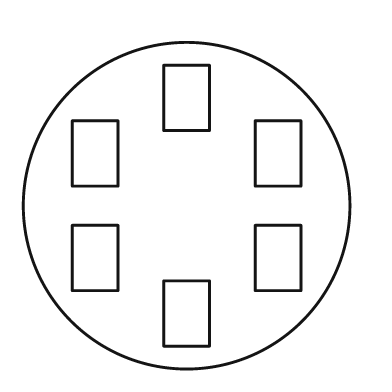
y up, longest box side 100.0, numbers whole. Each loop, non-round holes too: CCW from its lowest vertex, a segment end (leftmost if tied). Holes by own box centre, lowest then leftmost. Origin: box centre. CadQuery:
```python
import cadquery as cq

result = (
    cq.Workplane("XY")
    .moveTo(0.0, 0.0)
    .circle(50.0)
    .moveTo(-7.0, -43.0)
    .lineTo(7.0, -43.0)
    .lineTo(7.0, -23.0)
    .lineTo(-7.0, -23.0)
    .close()
    .moveTo(-35.0, -26.0)
    .lineTo(-21.0, -26.0)
    .lineTo(-21.0, -6.0)
    .lineTo(-35.0, -6.0)
    .close()
    .moveTo(21.0, -26.0)
    .lineTo(35.0, -26.0)
    .lineTo(35.0, -6.0)
    .lineTo(21.0, -6.0)
    .close()
    .moveTo(-35.0, 6.0)
    .lineTo(-21.0, 6.0)
    .lineTo(-21.0, 26.0)
    .lineTo(-35.0, 26.0)
    .close()
    .moveTo(21.0, 6.0)
    .lineTo(35.0, 6.0)
    .lineTo(35.0, 26.0)
    .lineTo(21.0, 26.0)
    .close()
    .moveTo(-7.0, 23.0)
    .lineTo(7.0, 23.0)
    .lineTo(7.0, 43.0)
    .lineTo(-7.0, 43.0)
    .close()
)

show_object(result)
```